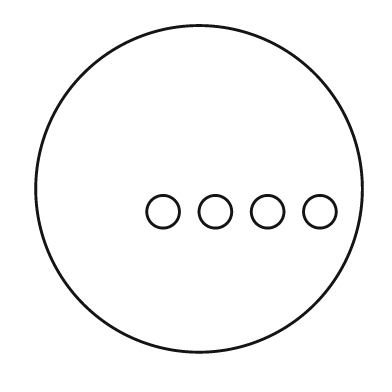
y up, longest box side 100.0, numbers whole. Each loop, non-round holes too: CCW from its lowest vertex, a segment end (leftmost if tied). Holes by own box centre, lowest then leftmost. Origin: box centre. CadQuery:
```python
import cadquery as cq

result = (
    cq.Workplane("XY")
    .moveTo(0.0, 0.0)
    .circle(50.0)
    .moveTo(-11.0, -7.0)
    .circle(5.0)
    .moveTo(5.0, -7.0)
    .circle(5.0)
    .moveTo(21.0, -7.0)
    .circle(5.0)
    .moveTo(37.0, -7.0)
    .circle(5.0)
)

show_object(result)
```